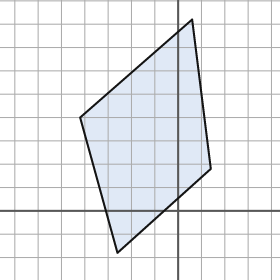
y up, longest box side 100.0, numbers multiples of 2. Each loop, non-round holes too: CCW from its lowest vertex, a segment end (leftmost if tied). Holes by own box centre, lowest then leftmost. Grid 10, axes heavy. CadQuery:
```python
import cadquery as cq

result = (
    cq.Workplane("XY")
    .moveTo(-26.0, -18.0)
    .lineTo(14.0, 18.0)
    .lineTo(6.0, 82.0)
    .lineTo(-42.0, 40.0)
    .close()
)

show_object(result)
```